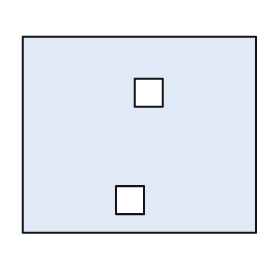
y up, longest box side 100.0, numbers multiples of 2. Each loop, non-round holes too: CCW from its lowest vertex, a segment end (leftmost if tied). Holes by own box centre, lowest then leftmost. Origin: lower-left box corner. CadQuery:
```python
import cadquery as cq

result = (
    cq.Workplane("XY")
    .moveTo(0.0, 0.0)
    .lineTo(100.0, 0.0)
    .lineTo(100.0, 84.0)
    .lineTo(0.0, 84.0)
    .close()
    .moveTo(40.0, 8.0)
    .lineTo(52.0, 8.0)
    .lineTo(52.0, 20.0)
    .lineTo(40.0, 20.0)
    .close()
    .moveTo(48.0, 54.0)
    .lineTo(60.0, 54.0)
    .lineTo(60.0, 66.0)
    .lineTo(48.0, 66.0)
    .close()
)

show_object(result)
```